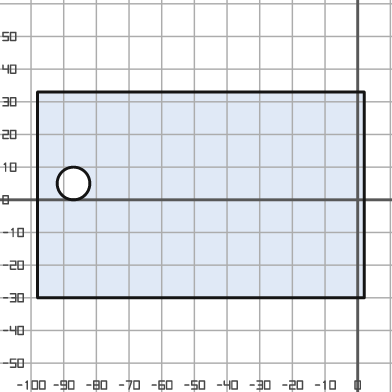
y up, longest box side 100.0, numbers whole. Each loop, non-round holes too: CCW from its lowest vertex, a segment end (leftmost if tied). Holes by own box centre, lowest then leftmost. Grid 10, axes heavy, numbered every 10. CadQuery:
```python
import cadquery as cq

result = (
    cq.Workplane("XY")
    .moveTo(-98.0, -30.0)
    .lineTo(2.0, -30.0)
    .lineTo(2.0, 33.0)
    .lineTo(-98.0, 33.0)
    .close()
    .moveTo(-87.0, 5.0)
    .circle(5.0)
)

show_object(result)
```